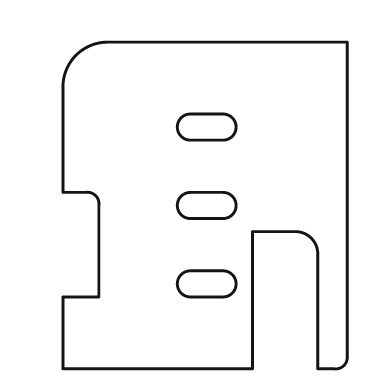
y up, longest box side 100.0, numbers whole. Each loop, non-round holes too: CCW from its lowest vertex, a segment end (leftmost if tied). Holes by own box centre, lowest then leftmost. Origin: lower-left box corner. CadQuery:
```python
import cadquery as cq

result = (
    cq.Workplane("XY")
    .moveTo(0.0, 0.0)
    .lineTo(58.0, 0.0)
    .lineTo(58.0, 42.0)
    .lineTo(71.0, 42.0)
    .threePointArc((76.0, 40.0), (78.0, 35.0))
    .lineTo(78.0, 0.0)
    .lineTo(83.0, 0.0)
    .threePointArc((86.0, 1.0), (87.0, 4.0))
    .lineTo(87.0, 100.0)
    .lineTo(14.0, 100.0)
    .threePointArc((4.0, 96.0), (0.0, 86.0))
    .lineTo(0.0, 54.0)
    .lineTo(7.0, 54.0)
    .threePointArc((10.0, 53.0), (11.0, 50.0))
    .lineTo(11.0, 22.0)
    .lineTo(0.0, 22.0)
    .close()
    .moveTo(39.0, 22.0)
    .lineTo(49.0, 22.0)
    .threePointArc((53.0, 26.0), (49.0, 30.0))
    .lineTo(39.0, 30.0)
    .threePointArc((35.0, 26.0), (39.0, 22.0))
    .close()
    .moveTo(39.0, 46.0)
    .lineTo(49.0, 46.0)
    .threePointArc((53.0, 50.0), (49.0, 54.0))
    .lineTo(39.0, 54.0)
    .threePointArc((35.0, 50.0), (39.0, 46.0))
    .close()
    .moveTo(39.0, 70.0)
    .lineTo(49.0, 70.0)
    .threePointArc((53.0, 74.0), (49.0, 78.0))
    .lineTo(39.0, 78.0)
    .threePointArc((35.0, 74.0), (39.0, 70.0))
    .close()
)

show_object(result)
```